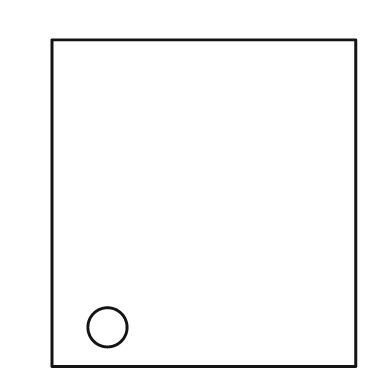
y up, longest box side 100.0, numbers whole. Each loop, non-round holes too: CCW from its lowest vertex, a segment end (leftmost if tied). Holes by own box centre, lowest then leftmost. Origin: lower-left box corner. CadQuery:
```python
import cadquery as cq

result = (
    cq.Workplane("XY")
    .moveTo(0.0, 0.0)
    .lineTo(93.0, 0.0)
    .lineTo(93.0, 100.0)
    .lineTo(0.0, 100.0)
    .close()
    .moveTo(17.0, 12.0)
    .circle(6.0)
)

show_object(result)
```